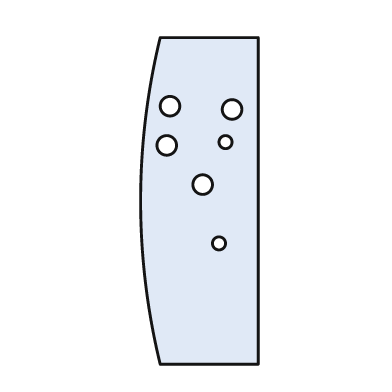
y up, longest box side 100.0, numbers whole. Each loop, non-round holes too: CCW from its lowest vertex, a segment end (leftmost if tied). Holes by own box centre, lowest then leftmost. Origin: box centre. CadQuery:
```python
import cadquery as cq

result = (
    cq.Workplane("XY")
    .moveTo(-12.0, -50.0)
    .lineTo(18.0, -50.0)
    .lineTo(18.0, 50.0)
    .lineTo(-12.0, 50.0)
    .threePointArc((-18.0, 0.0), (-12.0, -50.0))
    .close()
    .moveTo(6.0, -13.0)
    .circle(2.0)
    .moveTo(1.0, 5.0)
    .circle(3.0)
    .moveTo(-10.0, 17.0)
    .circle(3.0)
    .moveTo(8.0, 18.0)
    .circle(2.0)
    .moveTo(10.0, 28.0)
    .circle(3.0)
    .moveTo(-9.0, 29.0)
    .circle(3.0)
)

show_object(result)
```